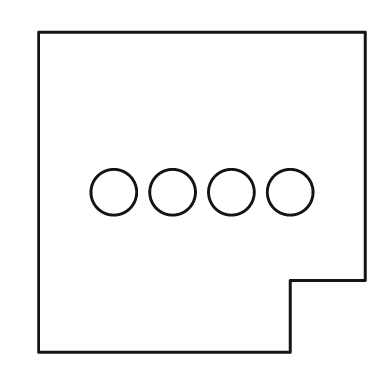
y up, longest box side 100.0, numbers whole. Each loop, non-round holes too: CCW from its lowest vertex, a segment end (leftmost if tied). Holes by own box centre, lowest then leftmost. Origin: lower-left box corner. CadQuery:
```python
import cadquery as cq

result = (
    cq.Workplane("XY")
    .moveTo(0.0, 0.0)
    .lineTo(77.0, 0.0)
    .lineTo(77.0, 22.0)
    .lineTo(100.0, 22.0)
    .lineTo(100.0, 98.0)
    .lineTo(0.0, 98.0)
    .close()
    .moveTo(23.0, 49.0)
    .circle(7.0)
    .moveTo(41.0, 49.0)
    .circle(7.0)
    .moveTo(59.0, 49.0)
    .circle(7.0)
    .moveTo(77.0, 49.0)
    .circle(7.0)
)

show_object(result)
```